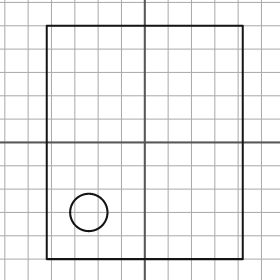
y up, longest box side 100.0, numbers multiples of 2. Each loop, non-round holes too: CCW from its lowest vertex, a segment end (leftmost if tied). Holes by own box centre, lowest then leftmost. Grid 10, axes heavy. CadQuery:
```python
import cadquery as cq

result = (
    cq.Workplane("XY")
    .moveTo(-42.0, -50.0)
    .lineTo(42.0, -50.0)
    .lineTo(42.0, 50.0)
    .lineTo(-42.0, 50.0)
    .close()
    .moveTo(-24.0, -30.0)
    .circle(8.0)
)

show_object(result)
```